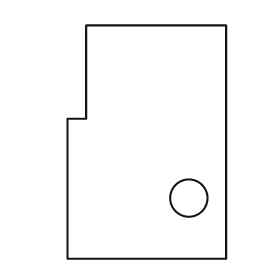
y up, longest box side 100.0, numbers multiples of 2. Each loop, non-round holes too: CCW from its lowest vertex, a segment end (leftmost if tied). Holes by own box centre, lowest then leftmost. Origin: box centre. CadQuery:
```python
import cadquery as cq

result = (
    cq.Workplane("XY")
    .moveTo(-34.0, -50.0)
    .lineTo(34.0, -50.0)
    .lineTo(34.0, 50.0)
    .lineTo(-26.0, 50.0)
    .lineTo(-26.0, 10.0)
    .lineTo(-34.0, 10.0)
    .close()
    .moveTo(18.0, -24.0)
    .circle(8.0)
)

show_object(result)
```